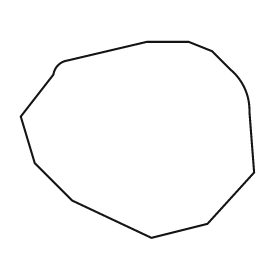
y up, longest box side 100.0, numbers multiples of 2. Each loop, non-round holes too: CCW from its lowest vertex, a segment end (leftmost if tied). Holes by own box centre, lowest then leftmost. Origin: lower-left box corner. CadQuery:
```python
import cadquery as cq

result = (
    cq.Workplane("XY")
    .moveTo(56.0, 0.0)
    .lineTo(80.0, 6.0)
    .lineTo(100.0, 28.0)
    .lineTo(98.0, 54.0)
    .threePointArc((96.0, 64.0), (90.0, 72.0))
    .lineTo(82.0, 80.0)
    .lineTo(72.0, 84.0)
    .lineTo(54.0, 84.0)
    .lineTo(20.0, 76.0)
    .threePointArc((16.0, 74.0), (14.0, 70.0))
    .lineTo(0.0, 52.0)
    .lineTo(6.0, 32.0)
    .lineTo(22.0, 16.0)
    .close()
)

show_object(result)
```